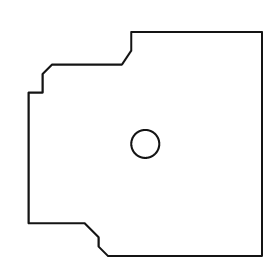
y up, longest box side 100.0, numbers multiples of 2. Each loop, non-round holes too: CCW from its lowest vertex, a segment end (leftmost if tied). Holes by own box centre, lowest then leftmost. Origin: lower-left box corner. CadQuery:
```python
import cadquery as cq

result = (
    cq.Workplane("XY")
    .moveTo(34.0, 0.0)
    .lineTo(100.0, 0.0)
    .lineTo(100.0, 96.0)
    .lineTo(44.0, 96.0)
    .lineTo(44.0, 88.0)
    .lineTo(40.0, 82.0)
    .lineTo(10.0, 82.0)
    .lineTo(6.0, 78.0)
    .lineTo(6.0, 70.0)
    .lineTo(0.0, 70.0)
    .lineTo(0.0, 14.0)
    .lineTo(24.0, 14.0)
    .lineTo(30.0, 8.0)
    .lineTo(30.0, 4.0)
    .close()
    .moveTo(50.0, 48.0)
    .circle(6.0)
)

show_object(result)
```